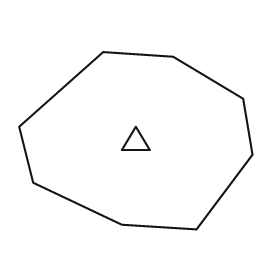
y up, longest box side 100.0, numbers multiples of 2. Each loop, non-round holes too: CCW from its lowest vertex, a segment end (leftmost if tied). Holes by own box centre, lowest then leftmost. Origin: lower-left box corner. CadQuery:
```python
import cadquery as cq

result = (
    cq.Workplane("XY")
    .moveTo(76.0, 0.0)
    .lineTo(100.0, 32.0)
    .lineTo(96.0, 56.0)
    .lineTo(66.0, 74.0)
    .lineTo(36.0, 76.0)
    .lineTo(0.0, 44.0)
    .lineTo(6.0, 20.0)
    .lineTo(44.0, 2.0)
    .close()
    .moveTo(44.0, 34.0)
    .lineTo(56.0, 34.0)
    .lineTo(50.0, 44.0)
    .close()
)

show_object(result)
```